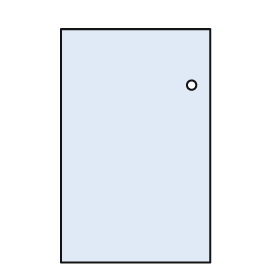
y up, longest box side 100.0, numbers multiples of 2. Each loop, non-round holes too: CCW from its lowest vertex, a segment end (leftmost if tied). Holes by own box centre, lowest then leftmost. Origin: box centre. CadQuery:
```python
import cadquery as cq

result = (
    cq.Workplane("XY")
    .moveTo(-32.0, -50.0)
    .lineTo(32.0, -50.0)
    .lineTo(32.0, 50.0)
    .lineTo(-32.0, 50.0)
    .close()
    .moveTo(24.0, 26.0)
    .circle(2.0)
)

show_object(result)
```